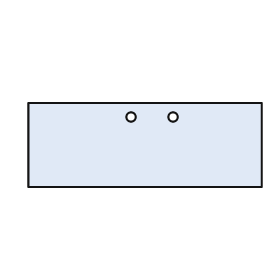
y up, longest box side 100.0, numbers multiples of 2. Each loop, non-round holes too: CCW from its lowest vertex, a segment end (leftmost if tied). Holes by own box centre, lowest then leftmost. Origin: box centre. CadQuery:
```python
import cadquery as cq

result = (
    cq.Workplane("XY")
    .moveTo(-50.0, -18.0)
    .lineTo(50.0, -18.0)
    .lineTo(50.0, 18.0)
    .lineTo(-50.0, 18.0)
    .close()
    .moveTo(-6.0, 12.0)
    .circle(2.0)
    .moveTo(12.0, 12.0)
    .circle(2.0)
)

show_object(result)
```